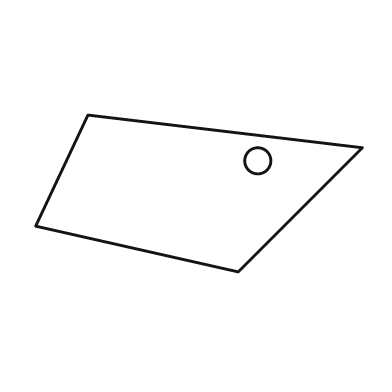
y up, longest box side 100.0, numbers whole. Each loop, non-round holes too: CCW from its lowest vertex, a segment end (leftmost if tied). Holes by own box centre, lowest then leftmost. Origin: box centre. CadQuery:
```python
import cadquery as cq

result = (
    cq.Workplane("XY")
    .moveTo(12.0, -24.0)
    .lineTo(50.0, 14.0)
    .lineTo(-34.0, 24.0)
    .lineTo(-50.0, -10.0)
    .close()
    .moveTo(18.0, 10.0)
    .circle(4.0)
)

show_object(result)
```